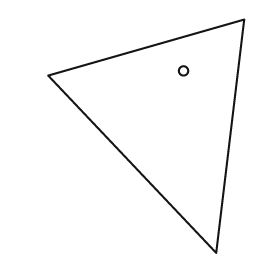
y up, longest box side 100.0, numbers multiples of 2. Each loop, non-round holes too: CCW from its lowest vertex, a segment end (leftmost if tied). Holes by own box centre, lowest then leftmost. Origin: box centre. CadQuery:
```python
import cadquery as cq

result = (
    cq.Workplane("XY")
    .moveTo(30.0, -50.0)
    .lineTo(42.0, 50.0)
    .lineTo(-42.0, 26.0)
    .close()
    .moveTo(16.0, 28.0)
    .circle(2.0)
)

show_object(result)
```